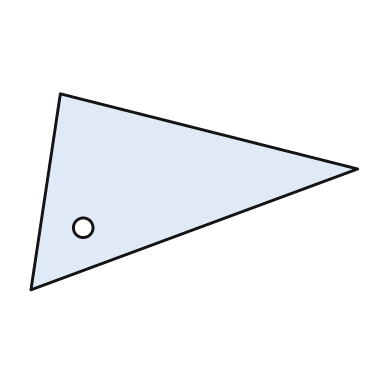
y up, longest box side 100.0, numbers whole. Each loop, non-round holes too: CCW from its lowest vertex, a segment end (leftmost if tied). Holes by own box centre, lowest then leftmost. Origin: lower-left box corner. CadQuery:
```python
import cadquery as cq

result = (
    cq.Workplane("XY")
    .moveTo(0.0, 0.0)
    .lineTo(100.0, 37.0)
    .lineTo(9.0, 60.0)
    .close()
    .moveTo(16.0, 19.0)
    .circle(3.0)
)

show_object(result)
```